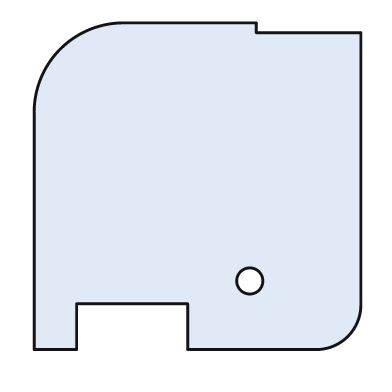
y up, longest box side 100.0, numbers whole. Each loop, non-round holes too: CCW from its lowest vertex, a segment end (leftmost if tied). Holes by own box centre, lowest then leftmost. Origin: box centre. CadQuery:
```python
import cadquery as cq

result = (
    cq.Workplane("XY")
    .moveTo(-50.0, -50.0)
    .lineTo(-37.0, -50.0)
    .lineTo(-37.0, -36.0)
    .lineTo(-3.0, -36.0)
    .lineTo(-3.0, -50.0)
    .lineTo(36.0, -50.0)
    .threePointArc((46.0, -46.0), (50.0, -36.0))
    .lineTo(50.0, 47.0)
    .lineTo(18.0, 47.0)
    .lineTo(18.0, 50.0)
    .lineTo(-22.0, 50.0)
    .threePointArc((-42.0, 42.0), (-50.0, 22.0))
    .close()
    .moveTo(16.0, -29.0)
    .circle(4.0)
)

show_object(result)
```